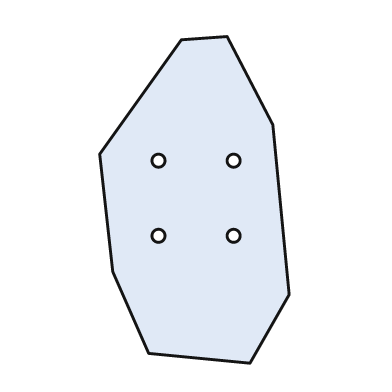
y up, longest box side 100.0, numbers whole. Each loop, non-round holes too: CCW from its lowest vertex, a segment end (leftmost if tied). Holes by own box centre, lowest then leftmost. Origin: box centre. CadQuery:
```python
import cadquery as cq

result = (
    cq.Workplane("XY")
    .moveTo(17.0, -50.0)
    .lineTo(29.0, -29.0)
    .lineTo(24.0, 23.0)
    .lineTo(10.0, 50.0)
    .lineTo(-4.0, 49.0)
    .lineTo(-29.0, 14.0)
    .lineTo(-25.0, -22.0)
    .lineTo(-14.0, -47.0)
    .close()
    .moveTo(-11.0, -11.0)
    .circle(2.0)
    .moveTo(12.0, -11.0)
    .circle(2.0)
    .moveTo(-11.0, 12.0)
    .circle(2.0)
    .moveTo(12.0, 12.0)
    .circle(2.0)
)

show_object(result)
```